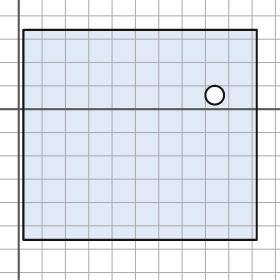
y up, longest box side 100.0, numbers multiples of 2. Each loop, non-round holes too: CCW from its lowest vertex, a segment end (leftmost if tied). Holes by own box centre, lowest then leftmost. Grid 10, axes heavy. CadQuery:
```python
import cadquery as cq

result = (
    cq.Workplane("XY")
    .moveTo(2.0, -56.0)
    .lineTo(102.0, -56.0)
    .lineTo(102.0, 34.0)
    .lineTo(2.0, 34.0)
    .close()
    .moveTo(84.0, 6.0)
    .circle(4.0)
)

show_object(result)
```